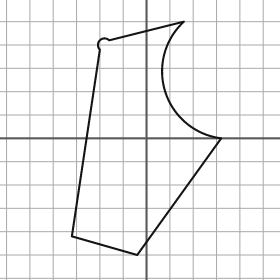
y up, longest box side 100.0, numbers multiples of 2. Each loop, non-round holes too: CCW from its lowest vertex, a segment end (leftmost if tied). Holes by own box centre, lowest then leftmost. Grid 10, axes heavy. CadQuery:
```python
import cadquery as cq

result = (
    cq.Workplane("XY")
    .moveTo(-4.0, -50.0)
    .lineTo(32.0, 0.0)
    .threePointArc((8.0, 20.0), (16.0, 50.0))
    .lineTo(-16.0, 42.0)
    .threePointArc((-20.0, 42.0), (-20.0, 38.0))
    .lineTo(-32.0, -42.0)
    .close()
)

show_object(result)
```